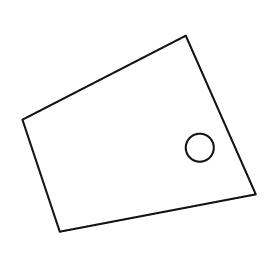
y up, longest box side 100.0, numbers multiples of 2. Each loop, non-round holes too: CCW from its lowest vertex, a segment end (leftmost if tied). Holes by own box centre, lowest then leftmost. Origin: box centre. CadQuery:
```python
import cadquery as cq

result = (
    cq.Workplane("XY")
    .moveTo(-34.0, -42.0)
    .lineTo(50.0, -26.0)
    .lineTo(20.0, 42.0)
    .lineTo(-50.0, 6.0)
    .close()
    .moveTo(26.0, -6.0)
    .circle(6.0)
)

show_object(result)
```